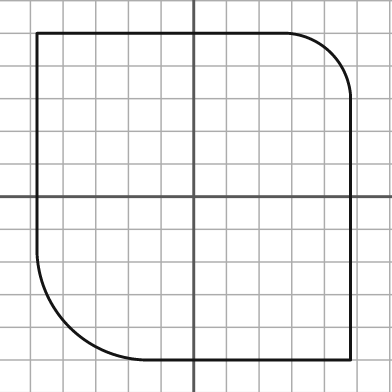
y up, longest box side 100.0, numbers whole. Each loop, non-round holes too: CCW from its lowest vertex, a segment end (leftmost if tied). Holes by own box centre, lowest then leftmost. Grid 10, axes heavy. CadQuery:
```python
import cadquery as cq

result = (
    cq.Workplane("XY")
    .moveTo(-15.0, -50.0)
    .lineTo(48.0, -50.0)
    .lineTo(48.0, 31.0)
    .threePointArc((42.0, 44.0), (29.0, 50.0))
    .lineTo(-48.0, 50.0)
    .lineTo(-48.0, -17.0)
    .threePointArc((-38.0, -40.0), (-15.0, -50.0))
    .close()
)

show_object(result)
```